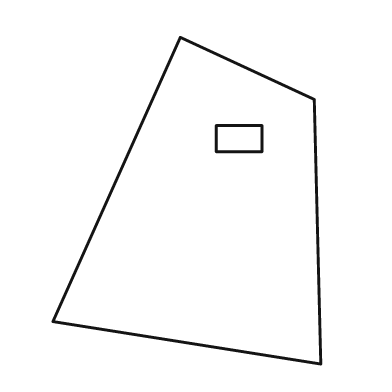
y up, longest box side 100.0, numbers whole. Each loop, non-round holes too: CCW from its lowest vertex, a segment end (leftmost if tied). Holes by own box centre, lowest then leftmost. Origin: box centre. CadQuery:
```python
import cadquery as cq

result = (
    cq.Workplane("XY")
    .moveTo(41.0, -50.0)
    .lineTo(39.0, 31.0)
    .lineTo(-2.0, 50.0)
    .lineTo(-41.0, -37.0)
    .close()
    .moveTo(9.0, 15.0)
    .lineTo(23.0, 15.0)
    .lineTo(23.0, 23.0)
    .lineTo(9.0, 23.0)
    .close()
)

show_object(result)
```